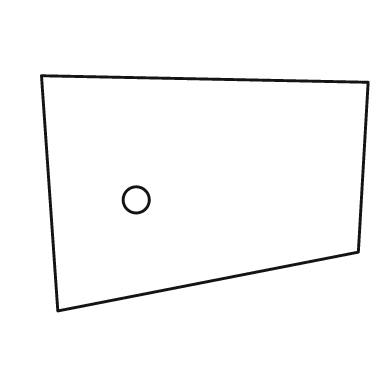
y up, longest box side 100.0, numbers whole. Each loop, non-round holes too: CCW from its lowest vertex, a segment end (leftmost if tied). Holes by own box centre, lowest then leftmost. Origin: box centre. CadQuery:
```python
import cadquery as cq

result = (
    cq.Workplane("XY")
    .moveTo(-45.0, -36.0)
    .lineTo(47.0, -18.0)
    .lineTo(50.0, 34.0)
    .lineTo(-50.0, 36.0)
    .close()
    .moveTo(-21.0, -2.0)
    .circle(4.0)
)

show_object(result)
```